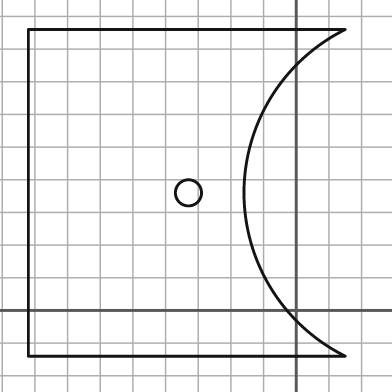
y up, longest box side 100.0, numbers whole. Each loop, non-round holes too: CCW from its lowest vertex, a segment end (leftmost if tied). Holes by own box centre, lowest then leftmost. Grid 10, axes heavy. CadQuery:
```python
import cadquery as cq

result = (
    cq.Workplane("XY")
    .moveTo(-82.0, -14.0)
    .lineTo(15.0, -14.0)
    .threePointArc((-16.0, 36.0), (15.0, 86.0))
    .lineTo(-82.0, 86.0)
    .close()
    .moveTo(-33.0, 36.0)
    .circle(4.0)
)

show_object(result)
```